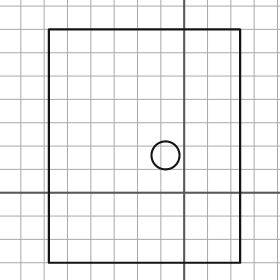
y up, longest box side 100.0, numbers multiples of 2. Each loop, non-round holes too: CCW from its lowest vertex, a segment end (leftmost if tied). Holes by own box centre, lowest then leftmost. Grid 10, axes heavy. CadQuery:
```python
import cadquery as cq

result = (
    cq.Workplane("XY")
    .moveTo(-58.0, -30.0)
    .lineTo(24.0, -30.0)
    .lineTo(24.0, 70.0)
    .lineTo(-58.0, 70.0)
    .close()
    .moveTo(-8.0, 16.0)
    .circle(6.0)
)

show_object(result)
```